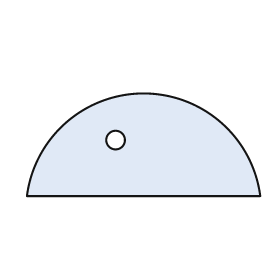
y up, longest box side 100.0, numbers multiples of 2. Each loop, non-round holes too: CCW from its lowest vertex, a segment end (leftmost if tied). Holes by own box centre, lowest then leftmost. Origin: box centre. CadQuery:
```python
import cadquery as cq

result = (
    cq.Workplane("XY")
    .moveTo(-50.0, -22.0)
    .lineTo(50.0, -22.0)
    .threePointArc((0.0, 22.0), (-50.0, -22.0))
    .close()
    .moveTo(-12.0, 2.0)
    .circle(4.0)
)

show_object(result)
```